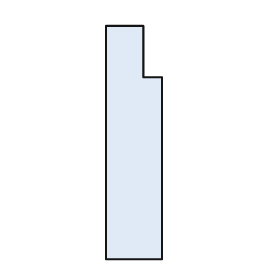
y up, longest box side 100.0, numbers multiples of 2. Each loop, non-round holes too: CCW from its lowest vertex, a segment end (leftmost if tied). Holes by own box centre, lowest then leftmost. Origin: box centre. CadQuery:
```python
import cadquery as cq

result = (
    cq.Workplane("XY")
    .moveTo(-12.0, -50.0)
    .lineTo(12.0, -50.0)
    .lineTo(12.0, 28.0)
    .lineTo(4.0, 28.0)
    .lineTo(4.0, 50.0)
    .lineTo(-12.0, 50.0)
    .close()
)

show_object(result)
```